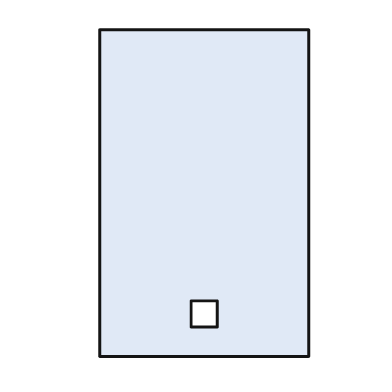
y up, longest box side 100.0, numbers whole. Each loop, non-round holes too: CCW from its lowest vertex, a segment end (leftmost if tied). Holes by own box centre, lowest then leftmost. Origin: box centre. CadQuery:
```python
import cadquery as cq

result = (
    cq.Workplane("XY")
    .moveTo(-32.0, -50.0)
    .lineTo(32.0, -50.0)
    .lineTo(32.0, 50.0)
    .lineTo(-32.0, 50.0)
    .close()
    .moveTo(-4.0, -41.0)
    .lineTo(4.0, -41.0)
    .lineTo(4.0, -33.0)
    .lineTo(-4.0, -33.0)
    .close()
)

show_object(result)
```